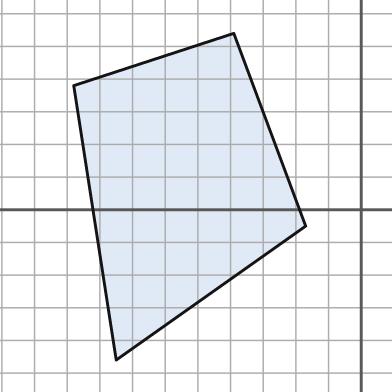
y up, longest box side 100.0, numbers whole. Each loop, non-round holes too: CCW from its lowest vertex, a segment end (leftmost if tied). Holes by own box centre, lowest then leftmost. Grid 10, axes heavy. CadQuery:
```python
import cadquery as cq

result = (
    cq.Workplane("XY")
    .moveTo(-75.0, -46.0)
    .lineTo(-17.0, -5.0)
    .lineTo(-39.0, 54.0)
    .lineTo(-88.0, 38.0)
    .close()
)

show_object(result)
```